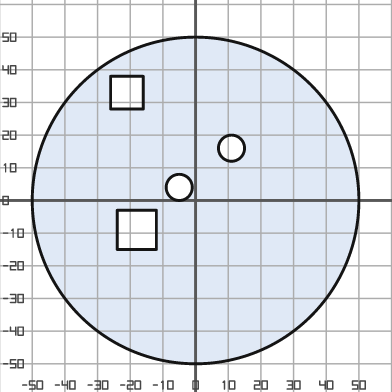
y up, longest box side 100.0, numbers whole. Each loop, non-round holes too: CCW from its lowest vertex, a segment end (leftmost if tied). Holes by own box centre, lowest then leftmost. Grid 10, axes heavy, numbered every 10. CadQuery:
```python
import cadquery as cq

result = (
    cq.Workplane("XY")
    .moveTo(0.0, 0.0)
    .circle(50.0)
    .moveTo(-24.0, -15.0)
    .lineTo(-12.0, -15.0)
    .lineTo(-12.0, -3.0)
    .lineTo(-24.0, -3.0)
    .close()
    .moveTo(-5.0, 4.0)
    .circle(4.0)
    .moveTo(11.0, 16.0)
    .circle(4.0)
    .moveTo(-26.0, 28.0)
    .lineTo(-16.0, 28.0)
    .lineTo(-16.0, 38.0)
    .lineTo(-26.0, 38.0)
    .close()
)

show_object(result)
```